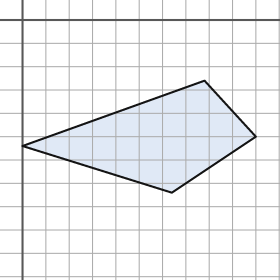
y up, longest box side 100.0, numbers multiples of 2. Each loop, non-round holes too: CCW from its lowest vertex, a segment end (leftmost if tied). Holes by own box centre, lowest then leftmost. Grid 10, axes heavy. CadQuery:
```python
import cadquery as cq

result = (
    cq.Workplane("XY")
    .moveTo(64.0, -74.0)
    .lineTo(100.0, -50.0)
    .lineTo(78.0, -26.0)
    .lineTo(0.0, -54.0)
    .close()
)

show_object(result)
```